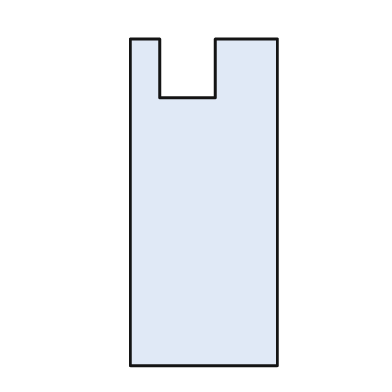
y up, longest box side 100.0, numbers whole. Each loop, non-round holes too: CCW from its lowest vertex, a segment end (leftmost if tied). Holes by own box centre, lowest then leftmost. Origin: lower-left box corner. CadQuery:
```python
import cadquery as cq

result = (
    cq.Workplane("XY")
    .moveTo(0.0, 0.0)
    .lineTo(45.0, 0.0)
    .lineTo(45.0, 100.0)
    .lineTo(26.0, 100.0)
    .lineTo(26.0, 82.0)
    .lineTo(9.0, 82.0)
    .lineTo(9.0, 100.0)
    .lineTo(0.0, 100.0)
    .close()
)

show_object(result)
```